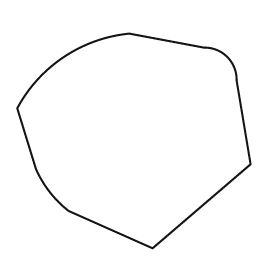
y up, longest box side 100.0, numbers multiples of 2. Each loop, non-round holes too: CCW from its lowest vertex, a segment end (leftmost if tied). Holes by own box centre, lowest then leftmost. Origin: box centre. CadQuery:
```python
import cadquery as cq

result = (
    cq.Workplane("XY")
    .moveTo(8.0, -46.0)
    .lineTo(50.0, -10.0)
    .lineTo(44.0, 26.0)
    .threePointArc((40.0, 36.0), (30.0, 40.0))
    .lineTo(-2.0, 46.0)
    .threePointArc((-30.0, 36.0), (-50.0, 14.0))
    .lineTo(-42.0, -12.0)
    .threePointArc((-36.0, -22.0), (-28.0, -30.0))
    .close()
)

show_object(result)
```